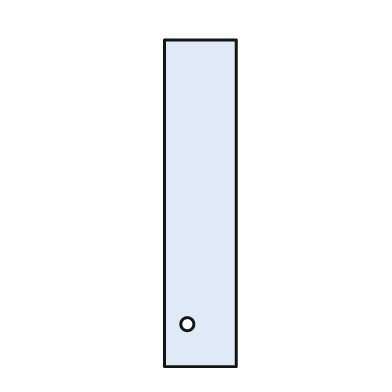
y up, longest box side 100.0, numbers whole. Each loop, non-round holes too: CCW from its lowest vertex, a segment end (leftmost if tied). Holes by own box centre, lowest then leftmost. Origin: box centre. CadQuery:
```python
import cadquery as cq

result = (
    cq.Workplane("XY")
    .moveTo(-11.0, -50.0)
    .lineTo(11.0, -50.0)
    .lineTo(11.0, 50.0)
    .lineTo(-11.0, 50.0)
    .close()
    .moveTo(-4.0, -37.0)
    .circle(2.0)
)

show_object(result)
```